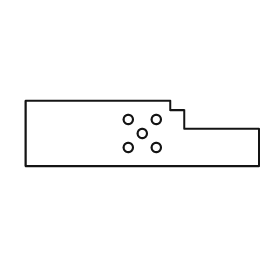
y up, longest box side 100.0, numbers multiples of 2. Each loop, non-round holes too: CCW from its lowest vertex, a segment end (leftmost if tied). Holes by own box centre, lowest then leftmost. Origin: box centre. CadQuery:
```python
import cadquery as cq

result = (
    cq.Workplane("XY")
    .moveTo(-50.0, -14.0)
    .lineTo(50.0, -14.0)
    .lineTo(50.0, 2.0)
    .lineTo(18.0, 2.0)
    .lineTo(18.0, 10.0)
    .lineTo(12.0, 10.0)
    .lineTo(12.0, 14.0)
    .lineTo(-50.0, 14.0)
    .close()
    .moveTo(-6.0, -6.0)
    .circle(2.0)
    .moveTo(6.0, -6.0)
    .circle(2.0)
    .moveTo(0.0, 0.0)
    .circle(2.0)
    .moveTo(-6.0, 6.0)
    .circle(2.0)
    .moveTo(6.0, 6.0)
    .circle(2.0)
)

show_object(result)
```